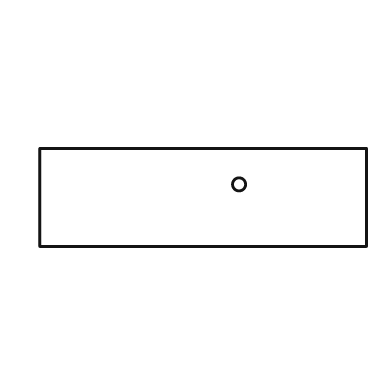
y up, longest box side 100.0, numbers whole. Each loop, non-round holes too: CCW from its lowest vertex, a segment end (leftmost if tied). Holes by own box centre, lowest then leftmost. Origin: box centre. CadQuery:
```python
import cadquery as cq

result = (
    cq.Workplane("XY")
    .moveTo(-50.0, -15.0)
    .lineTo(50.0, -15.0)
    .lineTo(50.0, 15.0)
    .lineTo(-50.0, 15.0)
    .close()
    .moveTo(11.0, 4.0)
    .circle(2.0)
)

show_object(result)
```